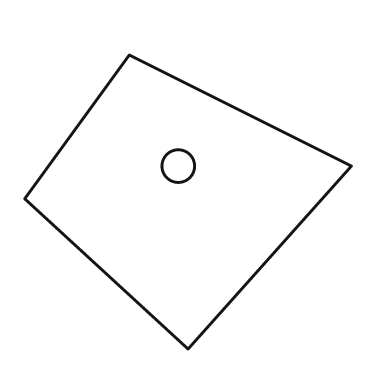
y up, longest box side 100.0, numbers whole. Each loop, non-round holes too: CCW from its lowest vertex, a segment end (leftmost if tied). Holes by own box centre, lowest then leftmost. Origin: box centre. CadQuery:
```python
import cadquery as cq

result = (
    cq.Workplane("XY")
    .moveTo(0.0, -45.0)
    .lineTo(50.0, 11.0)
    .lineTo(-18.0, 45.0)
    .lineTo(-50.0, 1.0)
    .close()
    .moveTo(-3.0, 11.0)
    .circle(5.0)
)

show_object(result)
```